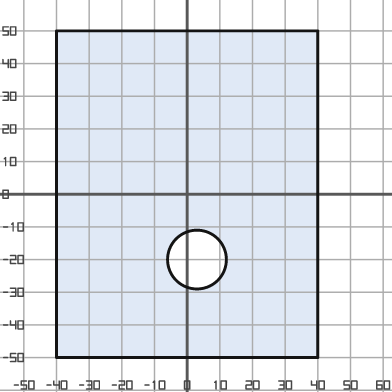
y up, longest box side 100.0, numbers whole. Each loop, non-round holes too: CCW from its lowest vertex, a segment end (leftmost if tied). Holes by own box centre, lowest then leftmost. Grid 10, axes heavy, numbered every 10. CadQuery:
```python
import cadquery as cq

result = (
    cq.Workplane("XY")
    .moveTo(-40.0, -50.0)
    .lineTo(40.0, -50.0)
    .lineTo(40.0, 50.0)
    .lineTo(-40.0, 50.0)
    .close()
    .moveTo(3.0, -20.0)
    .circle(9.0)
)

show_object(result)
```